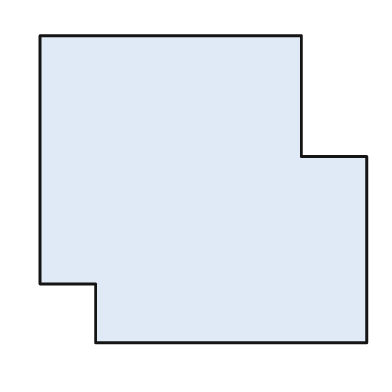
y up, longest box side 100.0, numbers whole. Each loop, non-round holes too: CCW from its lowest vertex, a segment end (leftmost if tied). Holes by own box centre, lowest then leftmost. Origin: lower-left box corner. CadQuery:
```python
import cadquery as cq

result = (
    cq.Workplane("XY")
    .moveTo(17.0, 0.0)
    .lineTo(100.0, 0.0)
    .lineTo(100.0, 57.0)
    .lineTo(80.0, 57.0)
    .lineTo(80.0, 94.0)
    .lineTo(0.0, 94.0)
    .lineTo(0.0, 18.0)
    .lineTo(17.0, 18.0)
    .close()
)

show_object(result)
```